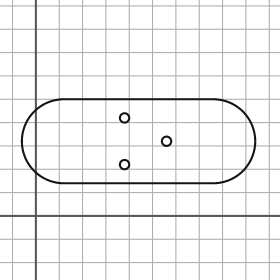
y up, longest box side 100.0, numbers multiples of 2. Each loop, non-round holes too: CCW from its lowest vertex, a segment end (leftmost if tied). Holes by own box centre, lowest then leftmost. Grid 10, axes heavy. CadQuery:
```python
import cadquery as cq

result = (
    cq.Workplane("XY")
    .moveTo(12.0, 14.0)
    .lineTo(76.0, 14.0)
    .threePointArc((94.0, 32.0), (76.0, 50.0))
    .lineTo(12.0, 50.0)
    .threePointArc((-6.0, 32.0), (12.0, 14.0))
    .close()
    .moveTo(38.0, 22.0)
    .circle(2.0)
    .moveTo(56.0, 32.0)
    .circle(2.0)
    .moveTo(38.0, 42.0)
    .circle(2.0)
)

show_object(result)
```